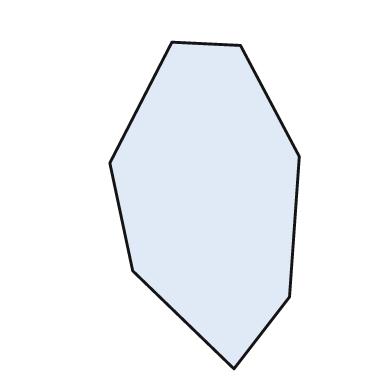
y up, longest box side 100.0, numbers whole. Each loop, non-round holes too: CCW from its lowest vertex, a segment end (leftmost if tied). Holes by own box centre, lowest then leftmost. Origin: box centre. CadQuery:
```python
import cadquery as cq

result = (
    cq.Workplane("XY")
    .moveTo(9.0, -50.0)
    .lineTo(26.0, -28.0)
    .lineTo(29.0, 15.0)
    .lineTo(11.0, 49.0)
    .lineTo(-10.0, 50.0)
    .lineTo(-29.0, 13.0)
    .lineTo(-22.0, -20.0)
    .close()
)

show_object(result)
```